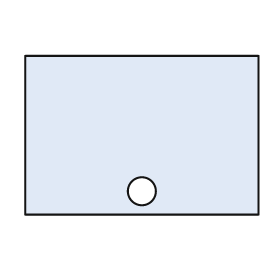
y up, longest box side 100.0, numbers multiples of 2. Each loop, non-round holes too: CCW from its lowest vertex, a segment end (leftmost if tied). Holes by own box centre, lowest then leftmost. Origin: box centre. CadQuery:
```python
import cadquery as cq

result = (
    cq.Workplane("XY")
    .moveTo(-50.0, -34.0)
    .lineTo(50.0, -34.0)
    .lineTo(50.0, 34.0)
    .lineTo(-50.0, 34.0)
    .close()
    .moveTo(0.0, -24.0)
    .circle(6.0)
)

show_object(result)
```